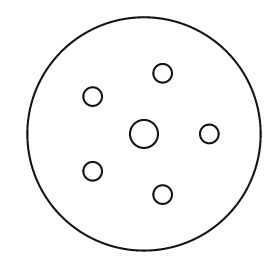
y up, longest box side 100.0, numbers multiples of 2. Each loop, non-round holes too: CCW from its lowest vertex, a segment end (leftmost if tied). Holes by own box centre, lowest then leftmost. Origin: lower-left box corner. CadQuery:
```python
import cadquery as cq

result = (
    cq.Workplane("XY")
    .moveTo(50.0, 50.0)
    .circle(50.0)
    .moveTo(58.0, 24.0)
    .circle(4.0)
    .moveTo(28.0, 34.0)
    .circle(4.0)
    .moveTo(50.0, 50.0)
    .circle(6.0)
    .moveTo(78.0, 50.0)
    .circle(4.0)
    .moveTo(28.0, 66.0)
    .circle(4.0)
    .moveTo(58.0, 76.0)
    .circle(4.0)
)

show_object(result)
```